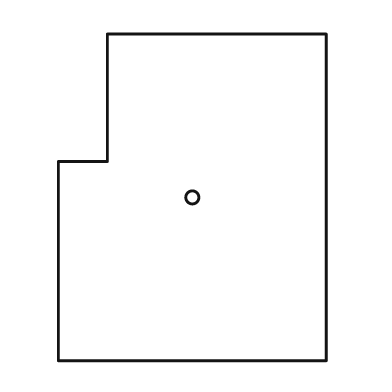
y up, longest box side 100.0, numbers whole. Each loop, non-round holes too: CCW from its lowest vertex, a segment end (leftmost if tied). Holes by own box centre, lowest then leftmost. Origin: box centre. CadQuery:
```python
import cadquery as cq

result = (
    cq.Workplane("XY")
    .moveTo(-41.0, -50.0)
    .lineTo(41.0, -50.0)
    .lineTo(41.0, 50.0)
    .lineTo(-26.0, 50.0)
    .lineTo(-26.0, 11.0)
    .lineTo(-41.0, 11.0)
    .close()
    .moveTo(0.0, 0.0)
    .circle(2.0)
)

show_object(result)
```